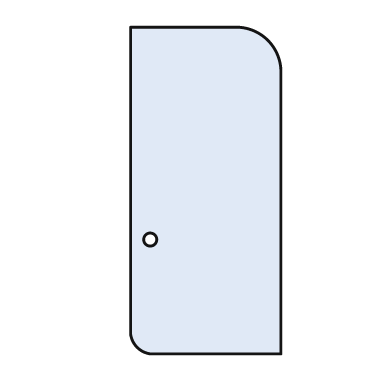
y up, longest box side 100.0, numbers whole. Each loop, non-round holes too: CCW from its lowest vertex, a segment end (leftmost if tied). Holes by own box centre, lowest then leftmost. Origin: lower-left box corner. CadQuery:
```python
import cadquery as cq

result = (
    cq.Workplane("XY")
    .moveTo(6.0, 0.0)
    .lineTo(46.0, 0.0)
    .lineTo(46.0, 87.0)
    .threePointArc((42.0, 96.0), (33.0, 100.0))
    .lineTo(0.0, 100.0)
    .lineTo(0.0, 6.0)
    .threePointArc((2.0, 2.0), (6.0, 0.0))
    .close()
    .moveTo(6.0, 35.0)
    .circle(2.0)
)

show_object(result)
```